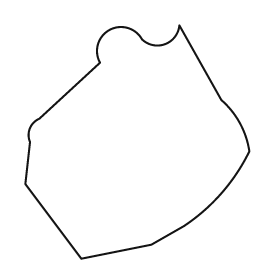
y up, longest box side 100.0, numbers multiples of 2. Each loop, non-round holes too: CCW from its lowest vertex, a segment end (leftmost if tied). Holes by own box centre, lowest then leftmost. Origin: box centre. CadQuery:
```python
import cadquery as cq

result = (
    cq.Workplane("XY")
    .moveTo(-24.0, -50.0)
    .lineTo(6.0, -44.0)
    .lineTo(20.0, -36.0)
    .threePointArc((36.0, -22.0), (48.0, -4.0))
    .threePointArc((44.0, 8.0), (36.0, 18.0))
    .lineTo(18.0, 50.0)
    .threePointArc((12.0, 42.0), (2.0, 44.0))
    .threePointArc((-12.0, 48.0), (-16.0, 34.0))
    .lineTo(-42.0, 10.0)
    .threePointArc((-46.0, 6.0), (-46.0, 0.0))
    .lineTo(-48.0, -18.0)
    .close()
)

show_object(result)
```